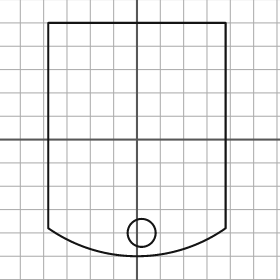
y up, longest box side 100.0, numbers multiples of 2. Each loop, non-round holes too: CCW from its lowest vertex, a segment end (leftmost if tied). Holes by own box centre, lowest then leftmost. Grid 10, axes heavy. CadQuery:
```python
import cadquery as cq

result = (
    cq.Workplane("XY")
    .moveTo(-38.0, -38.0)
    .threePointArc((0.0, -50.0), (38.0, -38.0))
    .lineTo(38.0, 50.0)
    .lineTo(-38.0, 50.0)
    .close()
    .moveTo(2.0, -40.0)
    .circle(6.0)
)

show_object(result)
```